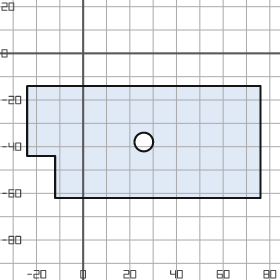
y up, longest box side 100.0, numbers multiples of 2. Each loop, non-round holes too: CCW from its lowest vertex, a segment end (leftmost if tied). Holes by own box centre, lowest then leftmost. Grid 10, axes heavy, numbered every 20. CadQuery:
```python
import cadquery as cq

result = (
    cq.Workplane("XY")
    .moveTo(-12.0, -62.0)
    .lineTo(76.0, -62.0)
    .lineTo(76.0, -14.0)
    .lineTo(-24.0, -14.0)
    .lineTo(-24.0, -44.0)
    .lineTo(-12.0, -44.0)
    .close()
    .moveTo(26.0, -38.0)
    .circle(4.0)
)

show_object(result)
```